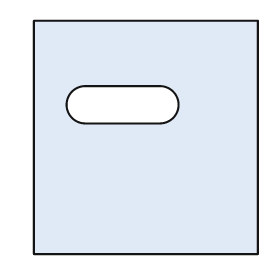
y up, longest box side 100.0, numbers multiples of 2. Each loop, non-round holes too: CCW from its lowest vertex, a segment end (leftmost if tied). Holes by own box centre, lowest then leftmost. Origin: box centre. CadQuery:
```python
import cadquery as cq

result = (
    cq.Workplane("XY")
    .moveTo(-48.0, -50.0)
    .lineTo(48.0, -50.0)
    .lineTo(48.0, 50.0)
    .lineTo(-48.0, 50.0)
    .close()
    .moveTo(-26.0, 6.0)
    .lineTo(6.0, 6.0)
    .threePointArc((14.0, 14.0), (6.0, 22.0))
    .lineTo(-26.0, 22.0)
    .threePointArc((-34.0, 14.0), (-26.0, 6.0))
    .close()
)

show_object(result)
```